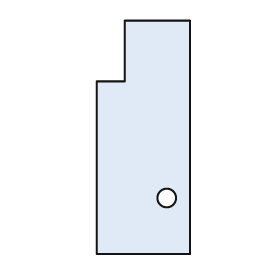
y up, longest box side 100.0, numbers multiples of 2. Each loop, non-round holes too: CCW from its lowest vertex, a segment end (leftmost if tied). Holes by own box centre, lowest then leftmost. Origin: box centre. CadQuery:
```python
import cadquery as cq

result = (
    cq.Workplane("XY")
    .moveTo(-20.0, -50.0)
    .lineTo(20.0, -50.0)
    .lineTo(20.0, 50.0)
    .lineTo(-8.0, 50.0)
    .lineTo(-8.0, 24.0)
    .lineTo(-20.0, 24.0)
    .close()
    .moveTo(10.0, -26.0)
    .circle(4.0)
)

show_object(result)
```